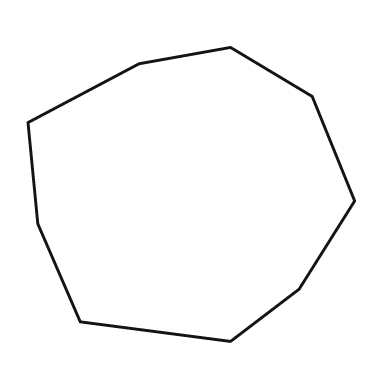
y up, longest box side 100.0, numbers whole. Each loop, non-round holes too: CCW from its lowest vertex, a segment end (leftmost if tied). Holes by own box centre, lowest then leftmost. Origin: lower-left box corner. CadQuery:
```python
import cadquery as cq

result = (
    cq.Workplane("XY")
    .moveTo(62.0, 0.0)
    .lineTo(83.0, 16.0)
    .lineTo(100.0, 43.0)
    .lineTo(87.0, 75.0)
    .lineTo(62.0, 90.0)
    .lineTo(34.0, 85.0)
    .lineTo(0.0, 67.0)
    .lineTo(3.0, 36.0)
    .lineTo(16.0, 6.0)
    .close()
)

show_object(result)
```